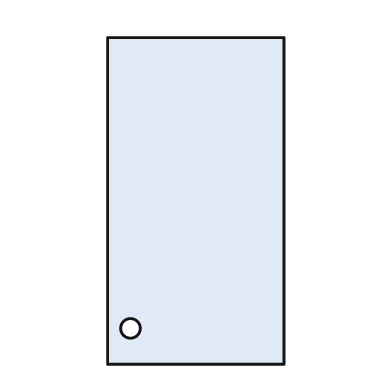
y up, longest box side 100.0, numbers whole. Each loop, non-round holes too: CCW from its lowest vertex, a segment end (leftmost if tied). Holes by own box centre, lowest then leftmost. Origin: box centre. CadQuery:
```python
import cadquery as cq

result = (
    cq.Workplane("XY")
    .moveTo(-27.0, -50.0)
    .lineTo(27.0, -50.0)
    .lineTo(27.0, 50.0)
    .lineTo(-27.0, 50.0)
    .close()
    .moveTo(-20.0, -39.0)
    .circle(3.0)
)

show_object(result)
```